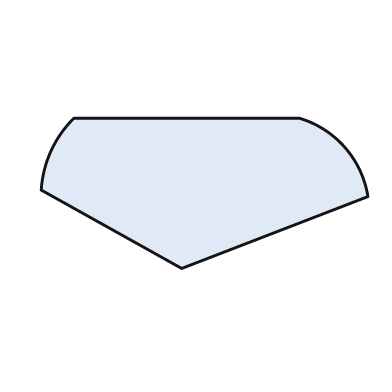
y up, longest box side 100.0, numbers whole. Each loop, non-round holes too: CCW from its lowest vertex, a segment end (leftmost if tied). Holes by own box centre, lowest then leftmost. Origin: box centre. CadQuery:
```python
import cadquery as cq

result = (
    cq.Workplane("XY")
    .moveTo(-7.0, -23.0)
    .lineTo(50.0, -1.0)
    .threePointArc((43.0, 14.0), (29.0, 23.0))
    .lineTo(-40.0, 23.0)
    .threePointArc((-47.0, 13.0), (-50.0, 1.0))
    .close()
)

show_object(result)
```